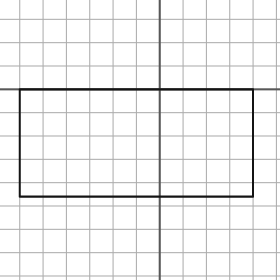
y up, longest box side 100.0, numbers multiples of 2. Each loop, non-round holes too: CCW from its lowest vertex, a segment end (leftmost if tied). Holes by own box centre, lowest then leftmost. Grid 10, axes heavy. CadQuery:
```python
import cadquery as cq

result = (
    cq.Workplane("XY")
    .moveTo(-60.0, -46.0)
    .lineTo(40.0, -46.0)
    .lineTo(40.0, 0.0)
    .lineTo(-60.0, 0.0)
    .close()
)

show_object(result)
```